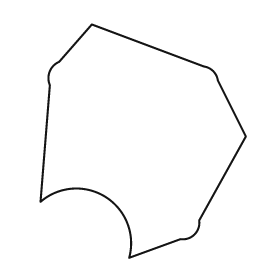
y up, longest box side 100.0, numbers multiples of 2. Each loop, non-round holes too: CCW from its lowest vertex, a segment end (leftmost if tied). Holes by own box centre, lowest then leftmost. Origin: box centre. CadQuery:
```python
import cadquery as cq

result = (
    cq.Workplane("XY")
    .moveTo(-6.0, -50.0)
    .lineTo(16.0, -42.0)
    .threePointArc((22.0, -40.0), (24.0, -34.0))
    .lineTo(44.0, 2.0)
    .lineTo(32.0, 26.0)
    .threePointArc((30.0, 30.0), (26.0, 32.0))
    .lineTo(-22.0, 50.0)
    .lineTo(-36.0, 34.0)
    .threePointArc((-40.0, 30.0), (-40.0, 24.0))
    .lineTo(-44.0, -26.0)
    .threePointArc((-16.0, -24.0), (-6.0, -50.0))
    .close()
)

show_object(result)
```